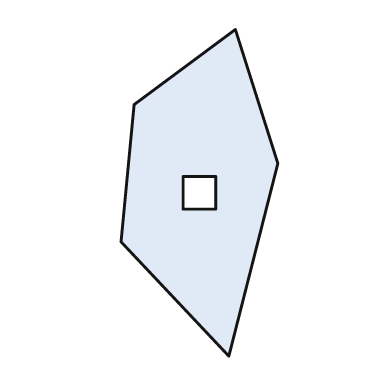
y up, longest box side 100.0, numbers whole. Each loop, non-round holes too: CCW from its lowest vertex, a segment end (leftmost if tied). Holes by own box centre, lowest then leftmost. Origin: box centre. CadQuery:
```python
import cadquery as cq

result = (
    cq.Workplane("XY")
    .moveTo(9.0, -50.0)
    .lineTo(24.0, 9.0)
    .lineTo(11.0, 50.0)
    .lineTo(-20.0, 27.0)
    .lineTo(-24.0, -15.0)
    .close()
    .moveTo(-5.0, -5.0)
    .lineTo(5.0, -5.0)
    .lineTo(5.0, 5.0)
    .lineTo(-5.0, 5.0)
    .close()
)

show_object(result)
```